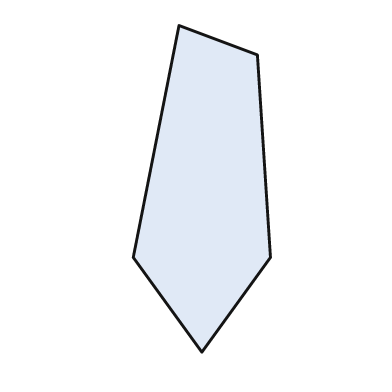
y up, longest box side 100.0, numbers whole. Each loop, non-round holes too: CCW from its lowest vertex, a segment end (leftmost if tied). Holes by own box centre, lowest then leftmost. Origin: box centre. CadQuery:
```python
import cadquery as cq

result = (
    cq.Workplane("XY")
    .moveTo(0.0, -50.0)
    .lineTo(21.0, -21.0)
    .lineTo(17.0, 41.0)
    .lineTo(-7.0, 50.0)
    .lineTo(-21.0, -21.0)
    .close()
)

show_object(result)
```